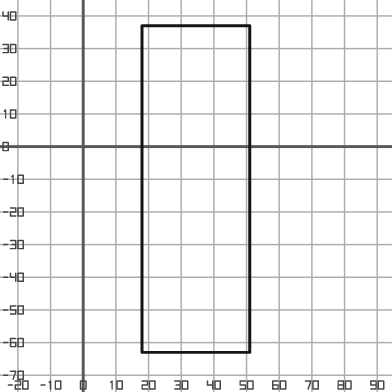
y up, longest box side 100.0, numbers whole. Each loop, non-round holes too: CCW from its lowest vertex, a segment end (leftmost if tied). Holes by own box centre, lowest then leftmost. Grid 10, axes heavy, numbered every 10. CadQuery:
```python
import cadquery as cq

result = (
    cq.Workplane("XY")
    .moveTo(18.0, -63.0)
    .lineTo(51.0, -63.0)
    .lineTo(51.0, 37.0)
    .lineTo(18.0, 37.0)
    .close()
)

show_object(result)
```